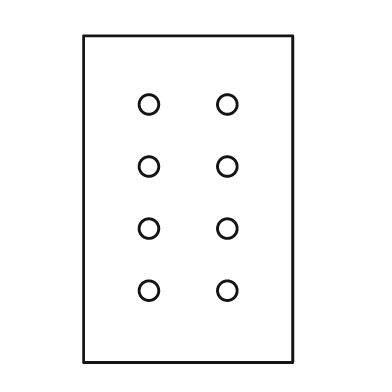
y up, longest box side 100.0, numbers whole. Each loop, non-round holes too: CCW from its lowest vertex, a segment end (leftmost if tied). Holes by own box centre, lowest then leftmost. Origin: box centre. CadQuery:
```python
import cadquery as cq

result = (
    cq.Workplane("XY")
    .moveTo(-32.0, -50.0)
    .lineTo(32.0, -50.0)
    .lineTo(32.0, 50.0)
    .lineTo(-32.0, 50.0)
    .close()
    .moveTo(-12.0, -28.0)
    .circle(3.0)
    .moveTo(12.0, -28.0)
    .circle(3.0)
    .moveTo(-12.0, -9.0)
    .circle(3.0)
    .moveTo(12.0, -9.0)
    .circle(3.0)
    .moveTo(-12.0, 10.0)
    .circle(3.0)
    .moveTo(12.0, 10.0)
    .circle(3.0)
    .moveTo(-12.0, 29.0)
    .circle(3.0)
    .moveTo(12.0, 29.0)
    .circle(3.0)
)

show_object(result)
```